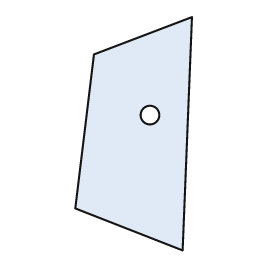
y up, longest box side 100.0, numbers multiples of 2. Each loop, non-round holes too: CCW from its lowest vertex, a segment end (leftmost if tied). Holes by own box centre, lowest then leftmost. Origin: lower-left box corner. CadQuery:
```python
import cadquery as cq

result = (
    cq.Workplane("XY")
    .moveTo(46.0, 0.0)
    .lineTo(50.0, 100.0)
    .lineTo(8.0, 84.0)
    .lineTo(0.0, 18.0)
    .close()
    .moveTo(32.0, 58.0)
    .circle(4.0)
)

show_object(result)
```